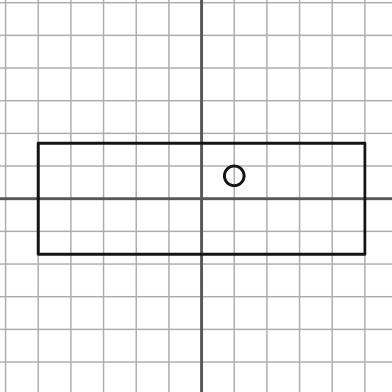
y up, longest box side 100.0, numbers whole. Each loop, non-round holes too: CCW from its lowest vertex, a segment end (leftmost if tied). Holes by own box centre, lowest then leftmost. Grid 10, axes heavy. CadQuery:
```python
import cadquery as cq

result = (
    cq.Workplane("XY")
    .moveTo(-50.0, -17.0)
    .lineTo(50.0, -17.0)
    .lineTo(50.0, 17.0)
    .lineTo(-50.0, 17.0)
    .close()
    .moveTo(10.0, 7.0)
    .circle(3.0)
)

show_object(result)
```